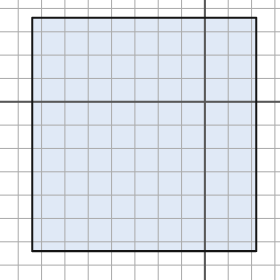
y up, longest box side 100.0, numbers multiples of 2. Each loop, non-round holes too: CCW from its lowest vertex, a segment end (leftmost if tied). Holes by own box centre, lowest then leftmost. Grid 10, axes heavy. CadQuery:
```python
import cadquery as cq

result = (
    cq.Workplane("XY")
    .moveTo(-74.0, -64.0)
    .lineTo(22.0, -64.0)
    .lineTo(22.0, 36.0)
    .lineTo(-74.0, 36.0)
    .close()
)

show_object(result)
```